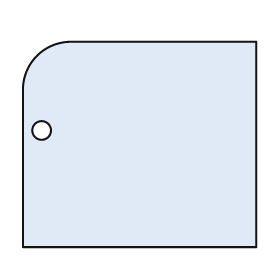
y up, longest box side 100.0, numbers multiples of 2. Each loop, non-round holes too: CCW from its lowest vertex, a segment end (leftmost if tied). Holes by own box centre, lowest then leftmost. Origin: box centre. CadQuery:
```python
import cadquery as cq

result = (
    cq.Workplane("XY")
    .moveTo(-50.0, -44.0)
    .lineTo(50.0, -44.0)
    .lineTo(50.0, 44.0)
    .lineTo(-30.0, 44.0)
    .threePointArc((-44.0, 38.0), (-50.0, 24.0))
    .close()
    .moveTo(-42.0, 6.0)
    .circle(4.0)
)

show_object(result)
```